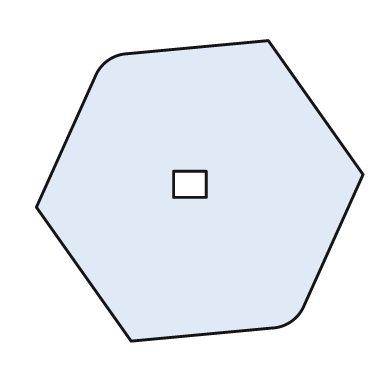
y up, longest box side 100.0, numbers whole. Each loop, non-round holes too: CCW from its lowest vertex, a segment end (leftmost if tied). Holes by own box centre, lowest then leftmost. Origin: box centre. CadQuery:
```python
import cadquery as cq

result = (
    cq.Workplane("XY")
    .moveTo(-21.0, -46.0)
    .lineTo(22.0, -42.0)
    .threePointArc((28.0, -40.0), (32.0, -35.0))
    .lineTo(50.0, 5.0)
    .lineTo(21.0, 46.0)
    .lineTo(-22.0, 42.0)
    .threePointArc((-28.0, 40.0), (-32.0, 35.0))
    .lineTo(-50.0, -5.0)
    .close()
    .moveTo(-8.0, -2.0)
    .lineTo(2.0, -2.0)
    .lineTo(2.0, 6.0)
    .lineTo(-8.0, 6.0)
    .close()
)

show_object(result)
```